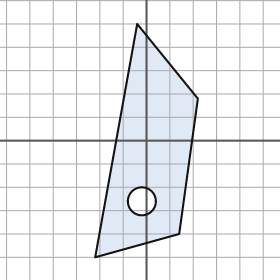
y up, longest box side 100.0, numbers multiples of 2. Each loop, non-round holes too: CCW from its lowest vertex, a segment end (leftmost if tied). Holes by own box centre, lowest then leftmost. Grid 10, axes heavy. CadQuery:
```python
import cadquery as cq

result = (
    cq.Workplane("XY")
    .moveTo(-22.0, -50.0)
    .lineTo(14.0, -40.0)
    .lineTo(22.0, 18.0)
    .lineTo(-4.0, 50.0)
    .close()
    .moveTo(-2.0, -26.0)
    .circle(6.0)
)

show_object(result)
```